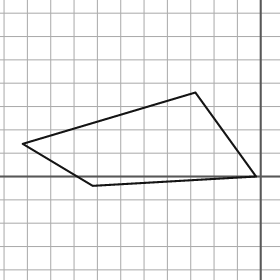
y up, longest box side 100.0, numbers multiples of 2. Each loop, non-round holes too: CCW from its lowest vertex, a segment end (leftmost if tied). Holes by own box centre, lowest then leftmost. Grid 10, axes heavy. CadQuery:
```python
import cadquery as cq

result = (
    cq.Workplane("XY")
    .moveTo(-72.0, -4.0)
    .lineTo(-2.0, 0.0)
    .lineTo(-28.0, 36.0)
    .lineTo(-102.0, 14.0)
    .close()
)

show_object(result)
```